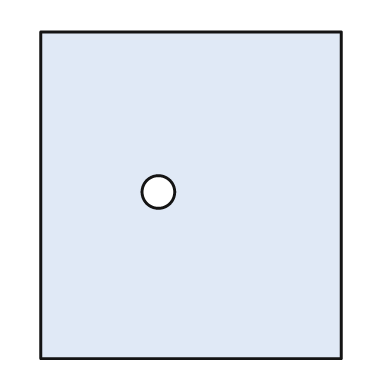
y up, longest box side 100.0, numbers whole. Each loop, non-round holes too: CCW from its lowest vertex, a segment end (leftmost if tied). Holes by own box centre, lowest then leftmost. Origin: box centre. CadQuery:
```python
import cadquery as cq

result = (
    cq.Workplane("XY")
    .moveTo(-46.0, -50.0)
    .lineTo(46.0, -50.0)
    .lineTo(46.0, 50.0)
    .lineTo(-46.0, 50.0)
    .close()
    .moveTo(-10.0, 1.0)
    .circle(5.0)
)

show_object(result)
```